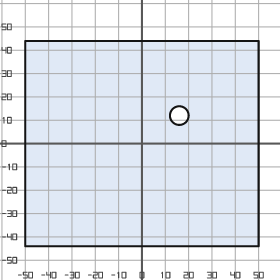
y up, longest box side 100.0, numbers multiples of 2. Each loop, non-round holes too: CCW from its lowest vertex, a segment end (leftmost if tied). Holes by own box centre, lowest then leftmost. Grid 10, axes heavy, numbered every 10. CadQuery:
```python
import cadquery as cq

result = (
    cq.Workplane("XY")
    .moveTo(-50.0, -44.0)
    .lineTo(50.0, -44.0)
    .lineTo(50.0, 44.0)
    .lineTo(-50.0, 44.0)
    .close()
    .moveTo(16.0, 12.0)
    .circle(4.0)
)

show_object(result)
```